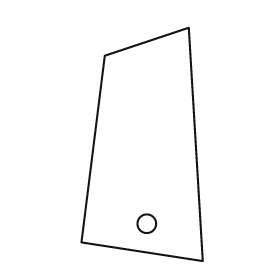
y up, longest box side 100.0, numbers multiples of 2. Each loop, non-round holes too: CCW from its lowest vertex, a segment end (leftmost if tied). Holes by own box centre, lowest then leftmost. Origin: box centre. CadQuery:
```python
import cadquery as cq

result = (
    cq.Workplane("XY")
    .moveTo(26.0, -50.0)
    .lineTo(20.0, 50.0)
    .lineTo(-16.0, 38.0)
    .lineTo(-26.0, -42.0)
    .close()
    .moveTo(2.0, -34.0)
    .circle(4.0)
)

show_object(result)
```